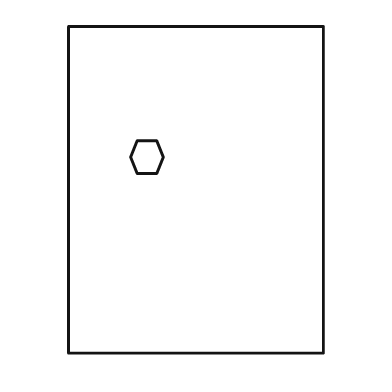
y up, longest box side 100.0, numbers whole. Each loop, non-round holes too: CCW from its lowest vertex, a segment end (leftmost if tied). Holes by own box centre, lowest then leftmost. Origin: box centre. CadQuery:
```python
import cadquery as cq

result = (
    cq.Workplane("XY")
    .moveTo(-39.0, -50.0)
    .lineTo(39.0, -50.0)
    .lineTo(39.0, 50.0)
    .lineTo(-39.0, 50.0)
    .close()
    .moveTo(-18.0, 5.0)
    .lineTo(-12.0, 5.0)
    .lineTo(-10.0, 10.0)
    .lineTo(-12.0, 15.0)
    .lineTo(-18.0, 15.0)
    .lineTo(-20.0, 10.0)
    .close()
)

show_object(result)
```